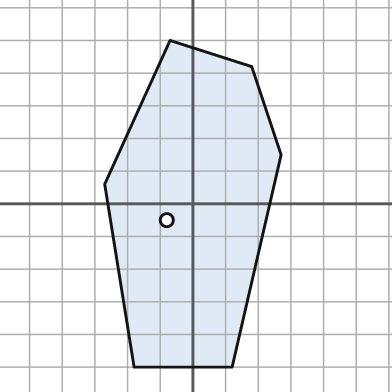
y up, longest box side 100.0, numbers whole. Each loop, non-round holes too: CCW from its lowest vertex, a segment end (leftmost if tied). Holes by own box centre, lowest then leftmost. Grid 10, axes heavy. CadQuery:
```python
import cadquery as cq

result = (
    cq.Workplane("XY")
    .moveTo(-18.0, -50.0)
    .lineTo(12.0, -50.0)
    .lineTo(27.0, 15.0)
    .lineTo(18.0, 42.0)
    .lineTo(-7.0, 50.0)
    .lineTo(-27.0, 6.0)
    .close()
    .moveTo(-8.0, -5.0)
    .circle(2.0)
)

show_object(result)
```